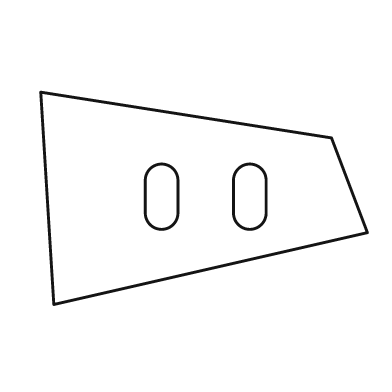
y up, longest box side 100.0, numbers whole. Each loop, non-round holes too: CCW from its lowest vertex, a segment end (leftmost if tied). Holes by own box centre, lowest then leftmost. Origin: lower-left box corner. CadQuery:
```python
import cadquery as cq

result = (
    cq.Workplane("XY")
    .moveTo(4.0, 0.0)
    .lineTo(100.0, 22.0)
    .lineTo(89.0, 51.0)
    .lineTo(0.0, 65.0)
    .close()
    .moveTo(32.0, 28.0)
    .threePointArc((37.0, 23.0), (42.0, 28.0))
    .lineTo(42.0, 38.0)
    .threePointArc((37.0, 43.0), (32.0, 38.0))
    .close()
    .moveTo(59.0, 28.0)
    .threePointArc((64.0, 23.0), (69.0, 28.0))
    .lineTo(69.0, 38.0)
    .threePointArc((64.0, 43.0), (59.0, 38.0))
    .close()
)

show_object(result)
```